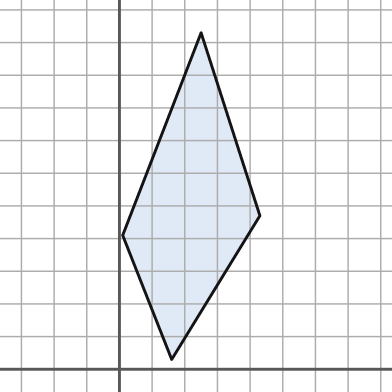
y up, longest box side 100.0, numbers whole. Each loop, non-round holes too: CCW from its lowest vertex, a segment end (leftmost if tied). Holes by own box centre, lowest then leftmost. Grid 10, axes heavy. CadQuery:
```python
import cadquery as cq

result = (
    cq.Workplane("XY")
    .moveTo(16.0, 3.0)
    .lineTo(43.0, 47.0)
    .lineTo(25.0, 103.0)
    .lineTo(1.0, 41.0)
    .close()
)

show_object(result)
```